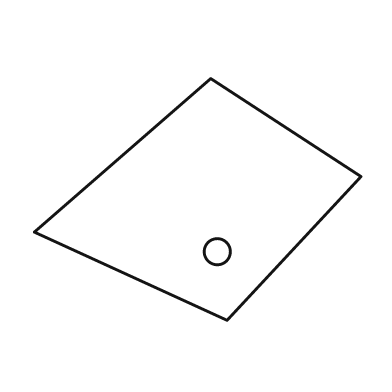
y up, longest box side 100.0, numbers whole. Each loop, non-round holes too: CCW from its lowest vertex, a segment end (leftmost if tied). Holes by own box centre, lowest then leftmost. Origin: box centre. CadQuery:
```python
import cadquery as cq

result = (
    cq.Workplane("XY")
    .moveTo(9.0, -37.0)
    .lineTo(50.0, 7.0)
    .lineTo(4.0, 37.0)
    .lineTo(-50.0, -10.0)
    .close()
    .moveTo(6.0, -16.0)
    .circle(4.0)
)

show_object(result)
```